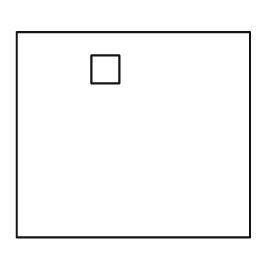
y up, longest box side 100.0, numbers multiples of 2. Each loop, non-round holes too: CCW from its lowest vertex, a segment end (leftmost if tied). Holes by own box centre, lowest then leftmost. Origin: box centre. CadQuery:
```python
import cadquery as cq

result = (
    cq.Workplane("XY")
    .moveTo(-50.0, -44.0)
    .lineTo(50.0, -44.0)
    .lineTo(50.0, 44.0)
    .lineTo(-50.0, 44.0)
    .close()
    .moveTo(-18.0, 22.0)
    .lineTo(-6.0, 22.0)
    .lineTo(-6.0, 34.0)
    .lineTo(-18.0, 34.0)
    .close()
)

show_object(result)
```